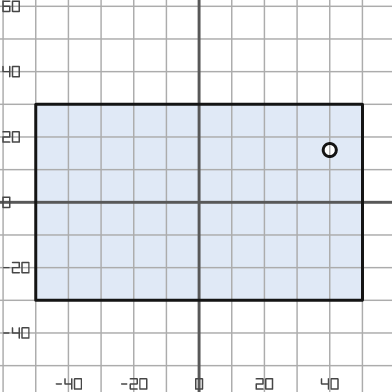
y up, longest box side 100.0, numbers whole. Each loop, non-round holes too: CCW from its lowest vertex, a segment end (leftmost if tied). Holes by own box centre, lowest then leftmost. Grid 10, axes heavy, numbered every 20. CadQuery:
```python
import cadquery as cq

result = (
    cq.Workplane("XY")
    .moveTo(-50.0, -30.0)
    .lineTo(50.0, -30.0)
    .lineTo(50.0, 30.0)
    .lineTo(-50.0, 30.0)
    .close()
    .moveTo(40.0, 16.0)
    .circle(2.0)
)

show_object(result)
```